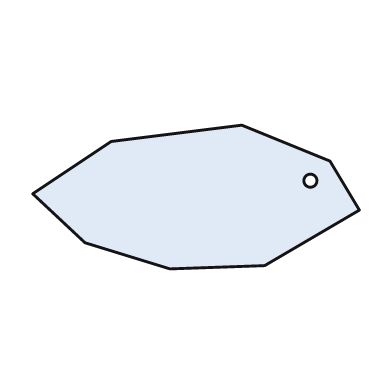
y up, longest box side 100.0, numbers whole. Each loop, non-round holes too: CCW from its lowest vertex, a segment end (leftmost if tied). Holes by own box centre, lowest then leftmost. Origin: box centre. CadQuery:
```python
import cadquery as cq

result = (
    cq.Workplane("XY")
    .moveTo(-8.0, -22.0)
    .lineTo(21.0, -21.0)
    .lineTo(50.0, -4.0)
    .lineTo(41.0, 11.0)
    .lineTo(14.0, 22.0)
    .lineTo(-26.0, 17.0)
    .lineTo(-50.0, 1.0)
    .lineTo(-34.0, -14.0)
    .close()
    .moveTo(35.0, 5.0)
    .circle(2.0)
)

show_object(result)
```